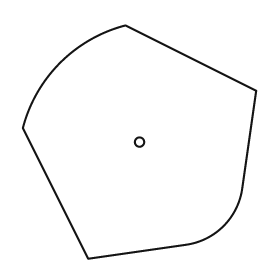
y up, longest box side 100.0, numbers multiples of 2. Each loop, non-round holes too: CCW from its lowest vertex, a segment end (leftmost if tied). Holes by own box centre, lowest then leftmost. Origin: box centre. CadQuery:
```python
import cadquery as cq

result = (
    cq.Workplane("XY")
    .moveTo(-22.0, -50.0)
    .lineTo(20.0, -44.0)
    .threePointArc((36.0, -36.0), (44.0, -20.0))
    .lineTo(50.0, 22.0)
    .lineTo(-6.0, 50.0)
    .threePointArc((-34.0, 34.0), (-50.0, 6.0))
    .close()
    .moveTo(0.0, 0.0)
    .circle(2.0)
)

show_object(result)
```